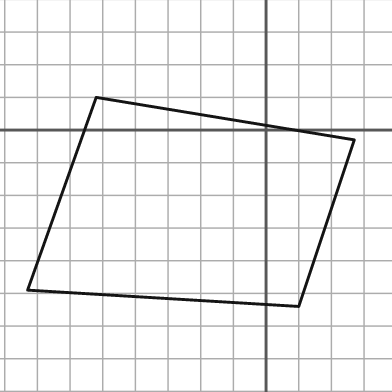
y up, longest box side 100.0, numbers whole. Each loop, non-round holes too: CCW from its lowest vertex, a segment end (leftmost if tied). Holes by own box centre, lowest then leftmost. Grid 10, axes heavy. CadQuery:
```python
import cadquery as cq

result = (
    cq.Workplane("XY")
    .moveTo(10.0, -54.0)
    .lineTo(27.0, -3.0)
    .lineTo(-52.0, 10.0)
    .lineTo(-73.0, -49.0)
    .close()
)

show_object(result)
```